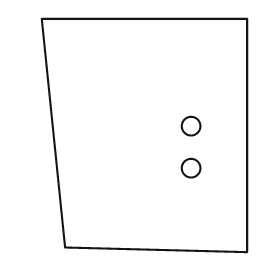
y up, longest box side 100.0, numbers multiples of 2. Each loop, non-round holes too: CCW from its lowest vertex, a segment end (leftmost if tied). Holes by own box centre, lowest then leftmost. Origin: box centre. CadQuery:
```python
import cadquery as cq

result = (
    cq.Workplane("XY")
    .moveTo(44.0, -50.0)
    .lineTo(44.0, 50.0)
    .lineTo(-44.0, 50.0)
    .lineTo(-34.0, -48.0)
    .close()
    .moveTo(20.0, -14.0)
    .circle(4.0)
    .moveTo(20.0, 4.0)
    .circle(4.0)
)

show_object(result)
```